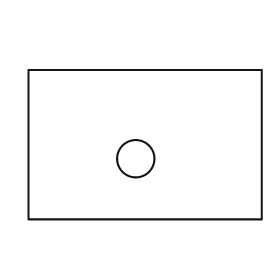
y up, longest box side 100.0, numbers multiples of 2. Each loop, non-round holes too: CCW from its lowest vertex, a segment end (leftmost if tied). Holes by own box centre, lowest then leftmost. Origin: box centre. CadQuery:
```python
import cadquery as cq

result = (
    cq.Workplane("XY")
    .moveTo(-50.0, -32.0)
    .lineTo(50.0, -32.0)
    .lineTo(50.0, 32.0)
    .lineTo(-50.0, 32.0)
    .close()
    .moveTo(-4.0, -6.0)
    .circle(8.0)
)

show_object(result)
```